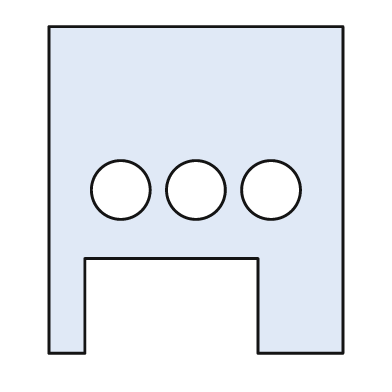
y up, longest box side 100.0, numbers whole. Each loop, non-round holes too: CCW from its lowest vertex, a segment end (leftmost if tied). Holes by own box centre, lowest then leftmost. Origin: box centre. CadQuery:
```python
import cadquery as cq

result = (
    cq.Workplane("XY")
    .moveTo(-45.0, -50.0)
    .lineTo(-34.0, -50.0)
    .lineTo(-34.0, -21.0)
    .lineTo(19.0, -21.0)
    .lineTo(19.0, -50.0)
    .lineTo(45.0, -50.0)
    .lineTo(45.0, 50.0)
    .lineTo(-45.0, 50.0)
    .close()
    .moveTo(-23.0, 0.0)
    .circle(9.0)
    .moveTo(0.0, 0.0)
    .circle(9.0)
    .moveTo(23.0, 0.0)
    .circle(9.0)
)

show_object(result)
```